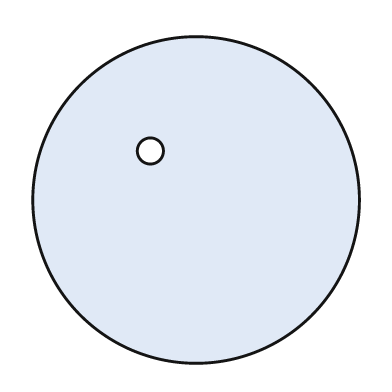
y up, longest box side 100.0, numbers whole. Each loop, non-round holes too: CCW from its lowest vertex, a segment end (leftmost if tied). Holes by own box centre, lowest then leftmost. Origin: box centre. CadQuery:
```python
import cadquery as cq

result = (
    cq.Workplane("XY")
    .moveTo(0.0, 0.0)
    .circle(50.0)
    .moveTo(-14.0, 15.0)
    .circle(4.0)
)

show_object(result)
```